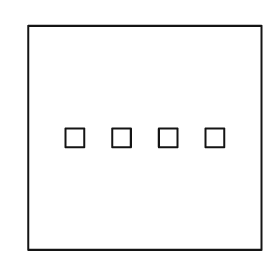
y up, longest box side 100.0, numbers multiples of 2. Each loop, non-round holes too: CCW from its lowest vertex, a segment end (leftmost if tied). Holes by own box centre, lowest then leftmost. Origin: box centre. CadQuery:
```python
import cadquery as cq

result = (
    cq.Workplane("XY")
    .moveTo(-50.0, -48.0)
    .lineTo(50.0, -48.0)
    .lineTo(50.0, 48.0)
    .lineTo(-50.0, 48.0)
    .close()
    .moveTo(-34.0, -4.0)
    .lineTo(-26.0, -4.0)
    .lineTo(-26.0, 4.0)
    .lineTo(-34.0, 4.0)
    .close()
    .moveTo(-14.0, -4.0)
    .lineTo(-6.0, -4.0)
    .lineTo(-6.0, 4.0)
    .lineTo(-14.0, 4.0)
    .close()
    .moveTo(6.0, -4.0)
    .lineTo(14.0, -4.0)
    .lineTo(14.0, 4.0)
    .lineTo(6.0, 4.0)
    .close()
    .moveTo(26.0, -4.0)
    .lineTo(34.0, -4.0)
    .lineTo(34.0, 4.0)
    .lineTo(26.0, 4.0)
    .close()
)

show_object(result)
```